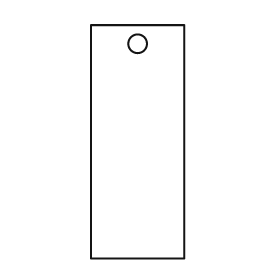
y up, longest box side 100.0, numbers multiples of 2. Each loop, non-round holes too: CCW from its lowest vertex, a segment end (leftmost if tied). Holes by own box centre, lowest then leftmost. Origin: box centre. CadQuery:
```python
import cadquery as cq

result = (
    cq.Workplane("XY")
    .moveTo(-20.0, -50.0)
    .lineTo(20.0, -50.0)
    .lineTo(20.0, 50.0)
    .lineTo(-20.0, 50.0)
    .close()
    .moveTo(0.0, 42.0)
    .circle(4.0)
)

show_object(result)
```